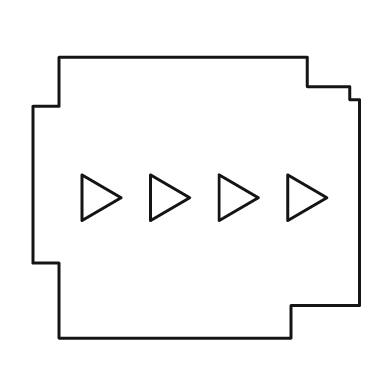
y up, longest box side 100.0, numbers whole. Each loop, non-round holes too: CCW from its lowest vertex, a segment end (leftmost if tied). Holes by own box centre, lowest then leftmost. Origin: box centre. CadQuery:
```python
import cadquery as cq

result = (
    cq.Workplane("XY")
    .moveTo(-42.0, -43.0)
    .lineTo(29.0, -43.0)
    .lineTo(29.0, -33.0)
    .lineTo(50.0, -33.0)
    .lineTo(50.0, 30.0)
    .lineTo(47.0, 30.0)
    .lineTo(47.0, 34.0)
    .lineTo(34.0, 34.0)
    .lineTo(34.0, 43.0)
    .lineTo(-42.0, 43.0)
    .lineTo(-42.0, 28.0)
    .lineTo(-50.0, 28.0)
    .lineTo(-50.0, -20.0)
    .lineTo(-42.0, -20.0)
    .close()
    .moveTo(-35.0, -7.0)
    .lineTo(-23.0, 0.0)
    .lineTo(-35.0, 7.0)
    .close()
    .moveTo(-14.0, -7.0)
    .lineTo(-2.0, 0.0)
    .lineTo(-14.0, 7.0)
    .close()
    .moveTo(7.0, -7.0)
    .lineTo(19.0, 0.0)
    .lineTo(7.0, 7.0)
    .close()
    .moveTo(28.0, -7.0)
    .lineTo(40.0, 0.0)
    .lineTo(28.0, 7.0)
    .close()
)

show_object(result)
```